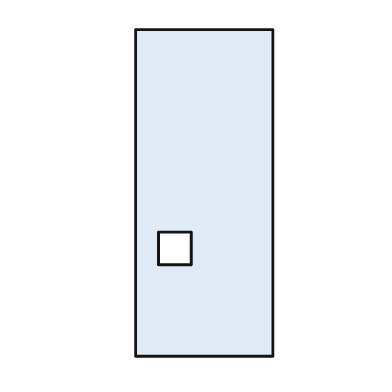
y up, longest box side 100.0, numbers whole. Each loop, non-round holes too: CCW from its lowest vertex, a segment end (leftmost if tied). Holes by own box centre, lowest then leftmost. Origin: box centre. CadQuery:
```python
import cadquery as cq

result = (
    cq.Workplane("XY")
    .moveTo(-21.0, -50.0)
    .lineTo(21.0, -50.0)
    .lineTo(21.0, 50.0)
    .lineTo(-21.0, 50.0)
    .close()
    .moveTo(-14.0, -22.0)
    .lineTo(-4.0, -22.0)
    .lineTo(-4.0, -12.0)
    .lineTo(-14.0, -12.0)
    .close()
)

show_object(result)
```